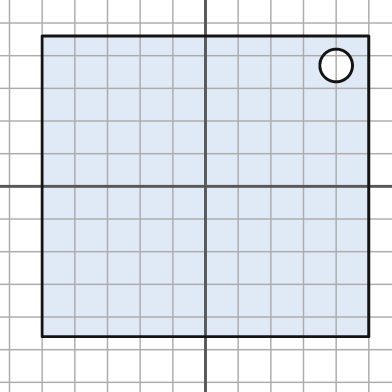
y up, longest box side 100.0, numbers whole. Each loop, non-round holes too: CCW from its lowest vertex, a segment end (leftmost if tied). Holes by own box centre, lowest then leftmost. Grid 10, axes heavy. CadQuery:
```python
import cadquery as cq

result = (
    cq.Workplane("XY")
    .moveTo(-50.0, -46.0)
    .lineTo(50.0, -46.0)
    .lineTo(50.0, 46.0)
    .lineTo(-50.0, 46.0)
    .close()
    .moveTo(40.0, 37.0)
    .circle(5.0)
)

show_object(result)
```